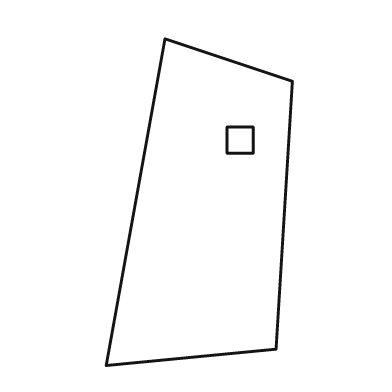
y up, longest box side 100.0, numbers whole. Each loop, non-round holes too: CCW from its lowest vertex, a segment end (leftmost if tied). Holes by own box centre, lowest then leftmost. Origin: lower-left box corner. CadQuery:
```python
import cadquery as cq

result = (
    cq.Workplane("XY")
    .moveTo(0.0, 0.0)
    .lineTo(52.0, 5.0)
    .lineTo(57.0, 87.0)
    .lineTo(18.0, 100.0)
    .close()
    .moveTo(37.0, 65.0)
    .lineTo(45.0, 65.0)
    .lineTo(45.0, 73.0)
    .lineTo(37.0, 73.0)
    .close()
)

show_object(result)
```